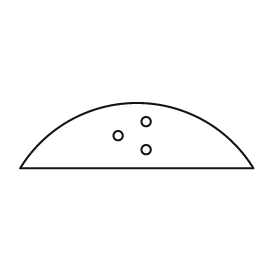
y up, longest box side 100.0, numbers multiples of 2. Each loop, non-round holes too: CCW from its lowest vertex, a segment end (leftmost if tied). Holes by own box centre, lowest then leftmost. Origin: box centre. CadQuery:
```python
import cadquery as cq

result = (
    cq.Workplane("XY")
    .moveTo(-50.0, -14.0)
    .lineTo(50.0, -14.0)
    .threePointArc((0.0, 14.0), (-50.0, -14.0))
    .close()
    .moveTo(4.0, -6.0)
    .circle(2.0)
    .moveTo(-8.0, 0.0)
    .circle(2.0)
    .moveTo(4.0, 6.0)
    .circle(2.0)
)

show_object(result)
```